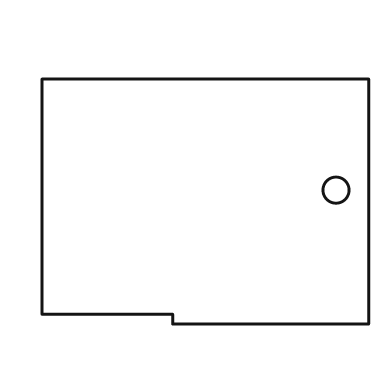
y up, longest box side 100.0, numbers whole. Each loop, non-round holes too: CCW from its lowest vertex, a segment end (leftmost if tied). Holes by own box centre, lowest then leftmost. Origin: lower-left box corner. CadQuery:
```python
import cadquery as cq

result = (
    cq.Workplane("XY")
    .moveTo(40.0, 0.0)
    .lineTo(100.0, 0.0)
    .lineTo(100.0, 75.0)
    .lineTo(0.0, 75.0)
    .lineTo(0.0, 3.0)
    .lineTo(40.0, 3.0)
    .close()
    .moveTo(90.0, 41.0)
    .circle(4.0)
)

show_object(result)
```